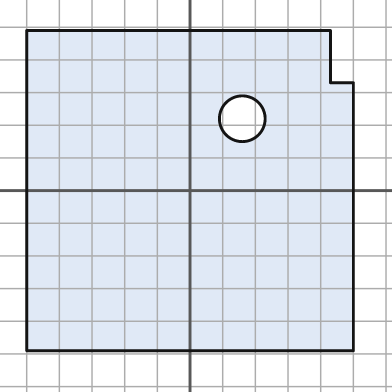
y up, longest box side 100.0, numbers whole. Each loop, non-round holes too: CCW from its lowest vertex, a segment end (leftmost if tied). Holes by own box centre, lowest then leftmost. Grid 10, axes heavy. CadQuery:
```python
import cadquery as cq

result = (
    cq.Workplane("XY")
    .moveTo(-50.0, -49.0)
    .lineTo(50.0, -49.0)
    .lineTo(50.0, 33.0)
    .lineTo(43.0, 33.0)
    .lineTo(43.0, 49.0)
    .lineTo(-50.0, 49.0)
    .close()
    .moveTo(16.0, 22.0)
    .circle(7.0)
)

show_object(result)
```